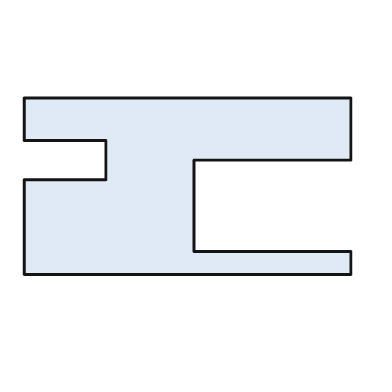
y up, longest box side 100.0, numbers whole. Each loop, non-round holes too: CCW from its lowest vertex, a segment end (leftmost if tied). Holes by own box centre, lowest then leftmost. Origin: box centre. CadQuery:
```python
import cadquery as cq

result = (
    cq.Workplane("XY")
    .moveTo(-50.0, -27.0)
    .lineTo(50.0, -27.0)
    .lineTo(50.0, -20.0)
    .lineTo(2.0, -20.0)
    .lineTo(2.0, 8.0)
    .lineTo(50.0, 8.0)
    .lineTo(50.0, 27.0)
    .lineTo(-50.0, 27.0)
    .lineTo(-50.0, 14.0)
    .lineTo(-25.0, 14.0)
    .lineTo(-25.0, 2.0)
    .lineTo(-50.0, 2.0)
    .close()
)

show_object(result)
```